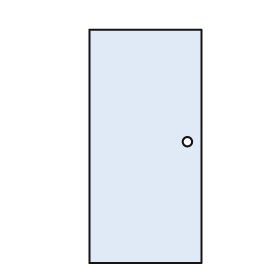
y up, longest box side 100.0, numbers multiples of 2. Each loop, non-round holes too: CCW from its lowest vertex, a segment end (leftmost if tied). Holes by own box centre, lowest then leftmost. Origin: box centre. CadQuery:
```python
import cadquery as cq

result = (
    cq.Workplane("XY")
    .moveTo(-24.0, -50.0)
    .lineTo(24.0, -50.0)
    .lineTo(24.0, 50.0)
    .lineTo(-24.0, 50.0)
    .close()
    .moveTo(18.0, 2.0)
    .circle(2.0)
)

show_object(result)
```